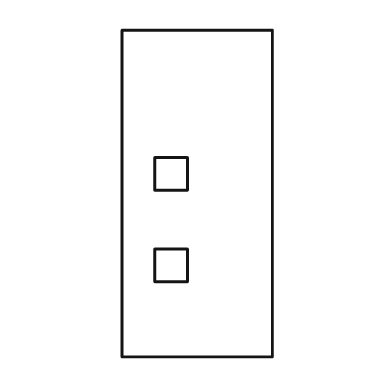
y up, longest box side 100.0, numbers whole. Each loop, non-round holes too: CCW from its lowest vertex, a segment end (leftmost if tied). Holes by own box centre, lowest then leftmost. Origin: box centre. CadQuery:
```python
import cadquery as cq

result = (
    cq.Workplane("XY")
    .moveTo(-23.0, -50.0)
    .lineTo(23.0, -50.0)
    .lineTo(23.0, 50.0)
    .lineTo(-23.0, 50.0)
    .close()
    .moveTo(-13.0, -27.0)
    .lineTo(-3.0, -27.0)
    .lineTo(-3.0, -17.0)
    .lineTo(-13.0, -17.0)
    .close()
    .moveTo(-13.0, 1.0)
    .lineTo(-3.0, 1.0)
    .lineTo(-3.0, 11.0)
    .lineTo(-13.0, 11.0)
    .close()
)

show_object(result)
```